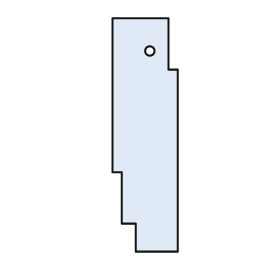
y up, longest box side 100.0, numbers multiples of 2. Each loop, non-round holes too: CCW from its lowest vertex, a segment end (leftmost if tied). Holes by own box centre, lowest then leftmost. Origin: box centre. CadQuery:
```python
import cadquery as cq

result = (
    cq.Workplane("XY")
    .moveTo(-4.0, -50.0)
    .lineTo(14.0, -50.0)
    .lineTo(14.0, 28.0)
    .lineTo(10.0, 28.0)
    .lineTo(10.0, 50.0)
    .lineTo(-14.0, 50.0)
    .lineTo(-14.0, -16.0)
    .lineTo(-10.0, -16.0)
    .lineTo(-10.0, -38.0)
    .lineTo(-4.0, -38.0)
    .close()
    .moveTo(2.0, 36.0)
    .circle(2.0)
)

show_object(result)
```